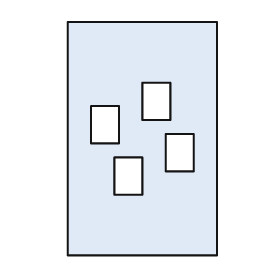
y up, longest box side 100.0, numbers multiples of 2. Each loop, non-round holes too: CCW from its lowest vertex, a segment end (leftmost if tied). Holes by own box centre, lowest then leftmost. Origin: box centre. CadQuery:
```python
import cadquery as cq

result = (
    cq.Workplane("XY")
    .moveTo(-32.0, -50.0)
    .lineTo(32.0, -50.0)
    .lineTo(32.0, 50.0)
    .lineTo(-32.0, 50.0)
    .close()
    .moveTo(-12.0, -24.0)
    .lineTo(0.0, -24.0)
    .lineTo(0.0, -8.0)
    .lineTo(-12.0, -8.0)
    .close()
    .moveTo(10.0, -14.0)
    .lineTo(22.0, -14.0)
    .lineTo(22.0, 2.0)
    .lineTo(10.0, 2.0)
    .close()
    .moveTo(-22.0, -2.0)
    .lineTo(-10.0, -2.0)
    .lineTo(-10.0, 14.0)
    .lineTo(-22.0, 14.0)
    .close()
    .moveTo(0.0, 8.0)
    .lineTo(12.0, 8.0)
    .lineTo(12.0, 24.0)
    .lineTo(0.0, 24.0)
    .close()
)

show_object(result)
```